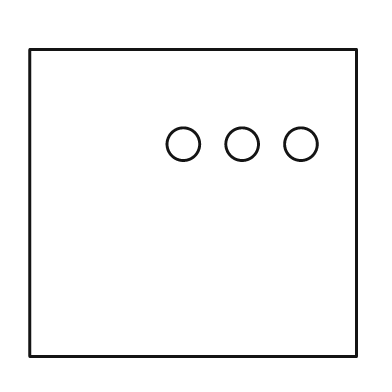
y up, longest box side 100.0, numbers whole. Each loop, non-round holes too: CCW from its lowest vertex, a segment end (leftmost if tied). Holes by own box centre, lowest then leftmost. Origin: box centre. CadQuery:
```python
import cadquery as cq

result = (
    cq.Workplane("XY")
    .moveTo(-50.0, -47.0)
    .lineTo(50.0, -47.0)
    .lineTo(50.0, 47.0)
    .lineTo(-50.0, 47.0)
    .close()
    .moveTo(-3.0, 18.0)
    .circle(5.0)
    .moveTo(15.0, 18.0)
    .circle(5.0)
    .moveTo(33.0, 18.0)
    .circle(5.0)
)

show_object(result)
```